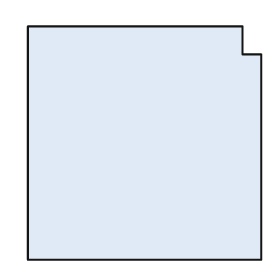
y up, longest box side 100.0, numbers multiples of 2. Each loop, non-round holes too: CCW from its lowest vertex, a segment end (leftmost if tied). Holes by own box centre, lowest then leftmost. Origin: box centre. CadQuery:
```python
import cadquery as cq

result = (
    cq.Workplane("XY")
    .moveTo(-50.0, -50.0)
    .lineTo(50.0, -50.0)
    .lineTo(50.0, 38.0)
    .lineTo(42.0, 38.0)
    .lineTo(42.0, 50.0)
    .lineTo(-50.0, 50.0)
    .close()
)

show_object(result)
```